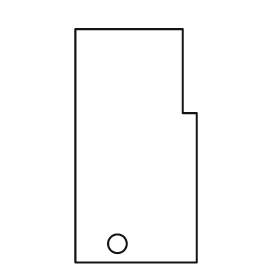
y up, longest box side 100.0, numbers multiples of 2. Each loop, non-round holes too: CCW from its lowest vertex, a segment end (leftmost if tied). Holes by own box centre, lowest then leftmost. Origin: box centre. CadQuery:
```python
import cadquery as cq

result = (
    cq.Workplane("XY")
    .moveTo(-26.0, -50.0)
    .lineTo(26.0, -50.0)
    .lineTo(26.0, 14.0)
    .lineTo(20.0, 14.0)
    .lineTo(20.0, 50.0)
    .lineTo(-26.0, 50.0)
    .close()
    .moveTo(-8.0, -42.0)
    .circle(4.0)
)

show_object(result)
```